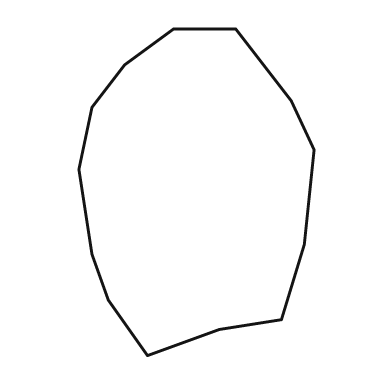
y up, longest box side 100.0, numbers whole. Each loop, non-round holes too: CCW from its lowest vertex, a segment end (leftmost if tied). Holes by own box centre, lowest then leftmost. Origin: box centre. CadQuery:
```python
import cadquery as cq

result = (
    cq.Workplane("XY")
    .moveTo(-15.0, -50.0)
    .lineTo(7.0, -42.0)
    .lineTo(26.0, -39.0)
    .lineTo(33.0, -16.0)
    .lineTo(36.0, 13.0)
    .lineTo(29.0, 28.0)
    .lineTo(12.0, 50.0)
    .lineTo(-7.0, 50.0)
    .lineTo(-22.0, 39.0)
    .lineTo(-32.0, 26.0)
    .lineTo(-36.0, 7.0)
    .lineTo(-32.0, -19.0)
    .lineTo(-27.0, -33.0)
    .close()
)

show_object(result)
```